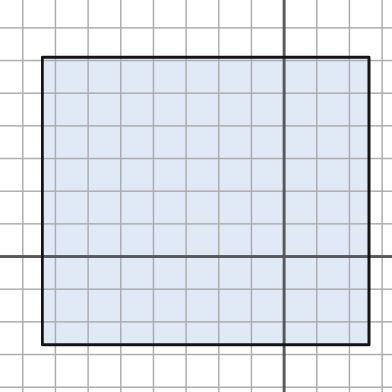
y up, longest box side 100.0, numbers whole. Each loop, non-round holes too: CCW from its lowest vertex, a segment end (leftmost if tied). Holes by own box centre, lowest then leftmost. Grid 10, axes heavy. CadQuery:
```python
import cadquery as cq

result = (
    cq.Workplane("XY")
    .moveTo(-74.0, -27.0)
    .lineTo(26.0, -27.0)
    .lineTo(26.0, 61.0)
    .lineTo(-74.0, 61.0)
    .close()
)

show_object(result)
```